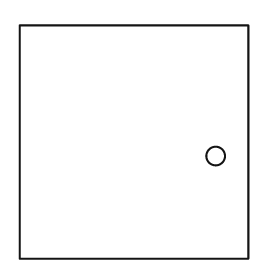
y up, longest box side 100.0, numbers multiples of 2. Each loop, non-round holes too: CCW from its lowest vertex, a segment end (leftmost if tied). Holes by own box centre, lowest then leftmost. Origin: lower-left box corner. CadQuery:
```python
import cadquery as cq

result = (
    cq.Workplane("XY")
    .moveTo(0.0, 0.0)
    .lineTo(98.0, 0.0)
    .lineTo(98.0, 100.0)
    .lineTo(0.0, 100.0)
    .close()
    .moveTo(84.0, 44.0)
    .circle(4.0)
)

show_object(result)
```